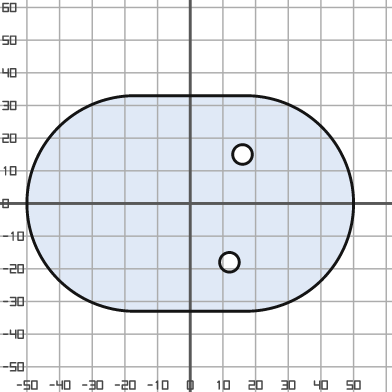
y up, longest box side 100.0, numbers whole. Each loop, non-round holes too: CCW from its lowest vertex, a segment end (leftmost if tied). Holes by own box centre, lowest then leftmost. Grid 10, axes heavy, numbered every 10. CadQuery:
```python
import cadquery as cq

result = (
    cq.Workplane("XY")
    .moveTo(-17.0, -33.0)
    .lineTo(17.0, -33.0)
    .threePointArc((50.0, 0.0), (17.0, 33.0))
    .lineTo(-17.0, 33.0)
    .threePointArc((-50.0, 0.0), (-17.0, -33.0))
    .close()
    .moveTo(12.0, -18.0)
    .circle(3.0)
    .moveTo(16.0, 15.0)
    .circle(3.0)
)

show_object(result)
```